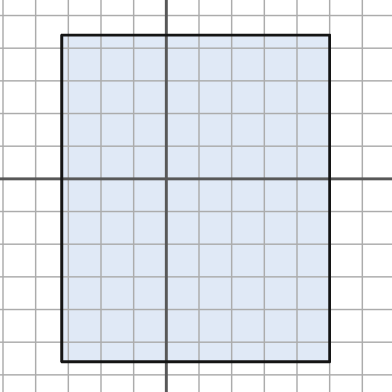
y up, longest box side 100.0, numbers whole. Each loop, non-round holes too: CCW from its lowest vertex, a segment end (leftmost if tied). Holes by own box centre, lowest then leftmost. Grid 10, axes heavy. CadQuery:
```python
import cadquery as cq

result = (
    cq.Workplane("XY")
    .moveTo(-32.0, -56.0)
    .lineTo(50.0, -56.0)
    .lineTo(50.0, 44.0)
    .lineTo(-32.0, 44.0)
    .close()
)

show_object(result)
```